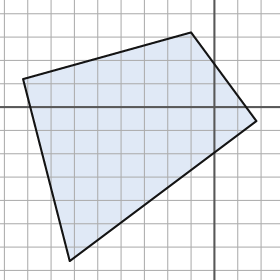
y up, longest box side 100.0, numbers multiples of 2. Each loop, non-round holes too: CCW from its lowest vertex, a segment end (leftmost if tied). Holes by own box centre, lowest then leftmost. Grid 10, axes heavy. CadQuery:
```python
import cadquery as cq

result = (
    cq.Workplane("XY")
    .moveTo(-62.0, -66.0)
    .lineTo(18.0, -6.0)
    .lineTo(-10.0, 32.0)
    .lineTo(-82.0, 12.0)
    .close()
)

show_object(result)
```